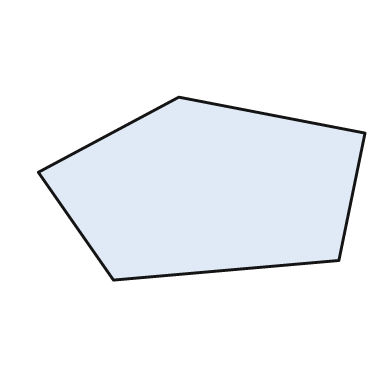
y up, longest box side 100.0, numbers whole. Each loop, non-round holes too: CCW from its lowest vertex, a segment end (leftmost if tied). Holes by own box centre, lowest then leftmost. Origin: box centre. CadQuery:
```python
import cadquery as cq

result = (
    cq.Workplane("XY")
    .moveTo(-27.0, -28.0)
    .lineTo(42.0, -22.0)
    .lineTo(50.0, 17.0)
    .lineTo(-7.0, 28.0)
    .lineTo(-50.0, 5.0)
    .close()
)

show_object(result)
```